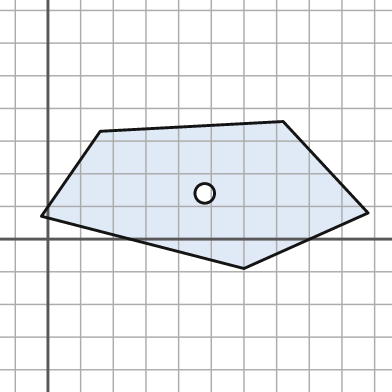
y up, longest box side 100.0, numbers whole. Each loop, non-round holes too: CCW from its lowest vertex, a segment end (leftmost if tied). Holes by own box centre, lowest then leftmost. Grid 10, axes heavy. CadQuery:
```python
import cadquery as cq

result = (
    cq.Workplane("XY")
    .moveTo(60.0, -9.0)
    .lineTo(98.0, 8.0)
    .lineTo(72.0, 36.0)
    .lineTo(16.0, 33.0)
    .lineTo(-2.0, 7.0)
    .close()
    .moveTo(48.0, 14.0)
    .circle(3.0)
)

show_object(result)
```